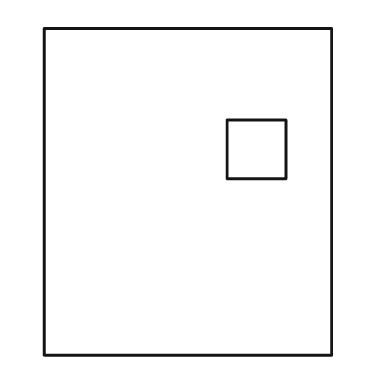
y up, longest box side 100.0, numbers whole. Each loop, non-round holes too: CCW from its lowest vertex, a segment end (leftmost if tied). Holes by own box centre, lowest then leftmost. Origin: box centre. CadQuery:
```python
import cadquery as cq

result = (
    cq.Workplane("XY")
    .moveTo(-44.0, -50.0)
    .lineTo(44.0, -50.0)
    .lineTo(44.0, 50.0)
    .lineTo(-44.0, 50.0)
    .close()
    .moveTo(12.0, 4.0)
    .lineTo(30.0, 4.0)
    .lineTo(30.0, 22.0)
    .lineTo(12.0, 22.0)
    .close()
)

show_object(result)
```